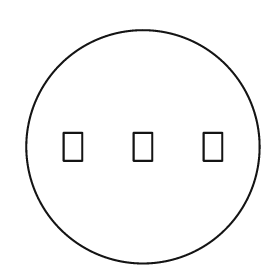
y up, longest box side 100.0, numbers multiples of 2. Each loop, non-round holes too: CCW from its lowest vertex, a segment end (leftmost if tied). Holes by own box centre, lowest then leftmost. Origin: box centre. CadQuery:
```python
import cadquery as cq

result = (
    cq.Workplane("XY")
    .moveTo(0.0, 0.0)
    .circle(50.0)
    .moveTo(-34.0, -6.0)
    .lineTo(-26.0, -6.0)
    .lineTo(-26.0, 6.0)
    .lineTo(-34.0, 6.0)
    .close()
    .moveTo(-4.0, -6.0)
    .lineTo(4.0, -6.0)
    .lineTo(4.0, 6.0)
    .lineTo(-4.0, 6.0)
    .close()
    .moveTo(26.0, -6.0)
    .lineTo(34.0, -6.0)
    .lineTo(34.0, 6.0)
    .lineTo(26.0, 6.0)
    .close()
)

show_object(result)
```